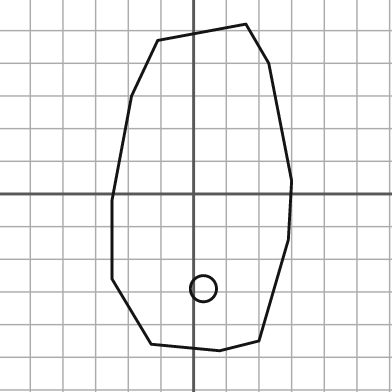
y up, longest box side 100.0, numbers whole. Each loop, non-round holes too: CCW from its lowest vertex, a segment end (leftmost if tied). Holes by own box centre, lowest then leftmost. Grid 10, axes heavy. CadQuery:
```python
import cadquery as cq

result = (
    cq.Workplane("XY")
    .moveTo(8.0, -48.0)
    .lineTo(20.0, -45.0)
    .lineTo(29.0, -14.0)
    .lineTo(30.0, 4.0)
    .lineTo(23.0, 40.0)
    .lineTo(16.0, 52.0)
    .lineTo(-11.0, 47.0)
    .lineTo(-19.0, 30.0)
    .lineTo(-25.0, -2.0)
    .lineTo(-25.0, -26.0)
    .lineTo(-13.0, -46.0)
    .close()
    .moveTo(3.0, -29.0)
    .circle(4.0)
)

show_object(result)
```